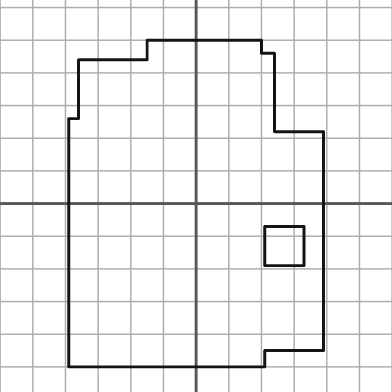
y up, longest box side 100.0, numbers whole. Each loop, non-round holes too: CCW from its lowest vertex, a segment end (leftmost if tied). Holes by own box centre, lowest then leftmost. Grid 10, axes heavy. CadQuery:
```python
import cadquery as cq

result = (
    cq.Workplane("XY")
    .moveTo(-39.0, -50.0)
    .lineTo(21.0, -50.0)
    .lineTo(21.0, -45.0)
    .lineTo(39.0, -45.0)
    .lineTo(39.0, 22.0)
    .lineTo(24.0, 22.0)
    .lineTo(24.0, 46.0)
    .lineTo(20.0, 46.0)
    .lineTo(20.0, 50.0)
    .lineTo(-15.0, 50.0)
    .lineTo(-15.0, 44.0)
    .lineTo(-36.0, 44.0)
    .lineTo(-36.0, 26.0)
    .lineTo(-39.0, 26.0)
    .close()
    .moveTo(21.0, -19.0)
    .lineTo(33.0, -19.0)
    .lineTo(33.0, -7.0)
    .lineTo(21.0, -7.0)
    .close()
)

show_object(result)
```